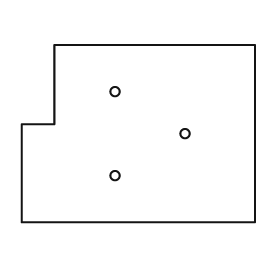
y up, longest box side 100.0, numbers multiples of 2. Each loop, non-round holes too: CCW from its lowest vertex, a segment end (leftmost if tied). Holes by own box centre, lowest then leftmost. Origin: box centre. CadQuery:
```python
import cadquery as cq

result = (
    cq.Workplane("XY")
    .moveTo(-50.0, -38.0)
    .lineTo(50.0, -38.0)
    .lineTo(50.0, 38.0)
    .lineTo(-36.0, 38.0)
    .lineTo(-36.0, 4.0)
    .lineTo(-50.0, 4.0)
    .close()
    .moveTo(-10.0, -18.0)
    .circle(2.0)
    .moveTo(20.0, 0.0)
    .circle(2.0)
    .moveTo(-10.0, 18.0)
    .circle(2.0)
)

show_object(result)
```